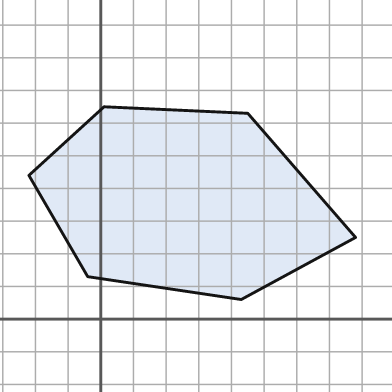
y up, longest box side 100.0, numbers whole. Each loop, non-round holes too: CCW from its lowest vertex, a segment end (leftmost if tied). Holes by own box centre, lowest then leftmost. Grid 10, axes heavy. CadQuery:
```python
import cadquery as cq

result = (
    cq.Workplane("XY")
    .moveTo(43.0, 6.0)
    .lineTo(78.0, 25.0)
    .lineTo(45.0, 63.0)
    .lineTo(1.0, 65.0)
    .lineTo(-22.0, 44.0)
    .lineTo(-4.0, 13.0)
    .close()
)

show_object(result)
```